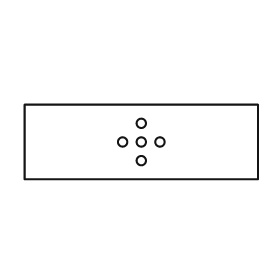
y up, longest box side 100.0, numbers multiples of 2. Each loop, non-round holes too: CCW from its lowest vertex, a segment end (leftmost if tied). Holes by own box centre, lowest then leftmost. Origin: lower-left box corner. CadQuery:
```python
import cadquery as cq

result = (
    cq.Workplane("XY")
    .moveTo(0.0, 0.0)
    .lineTo(100.0, 0.0)
    .lineTo(100.0, 32.0)
    .lineTo(0.0, 32.0)
    .close()
    .moveTo(50.0, 8.0)
    .circle(2.0)
    .moveTo(42.0, 16.0)
    .circle(2.0)
    .moveTo(50.0, 16.0)
    .circle(2.0)
    .moveTo(58.0, 16.0)
    .circle(2.0)
    .moveTo(50.0, 24.0)
    .circle(2.0)
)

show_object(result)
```